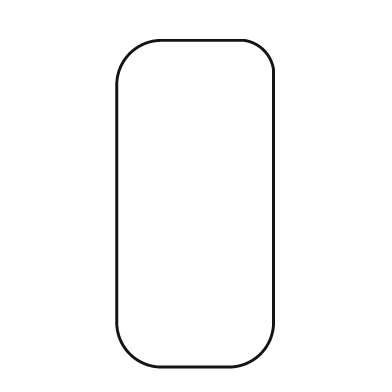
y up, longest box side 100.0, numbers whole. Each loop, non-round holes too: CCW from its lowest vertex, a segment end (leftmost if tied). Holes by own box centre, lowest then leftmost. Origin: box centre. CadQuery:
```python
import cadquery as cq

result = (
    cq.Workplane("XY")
    .moveTo(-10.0, -50.0)
    .lineTo(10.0, -50.0)
    .threePointArc((20.0, -46.0), (24.0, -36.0))
    .lineTo(24.0, 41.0)
    .threePointArc((21.0, 47.0), (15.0, 50.0))
    .lineTo(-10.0, 50.0)
    .threePointArc((-20.0, 46.0), (-24.0, 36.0))
    .lineTo(-24.0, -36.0)
    .threePointArc((-20.0, -46.0), (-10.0, -50.0))
    .close()
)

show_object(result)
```